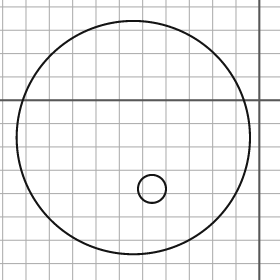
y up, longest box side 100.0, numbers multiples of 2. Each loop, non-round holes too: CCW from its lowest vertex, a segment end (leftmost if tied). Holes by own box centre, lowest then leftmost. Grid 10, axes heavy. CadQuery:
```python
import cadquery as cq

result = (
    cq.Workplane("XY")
    .moveTo(-54.0, -16.0)
    .circle(50.0)
    .moveTo(-46.0, -38.0)
    .circle(6.0)
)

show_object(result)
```